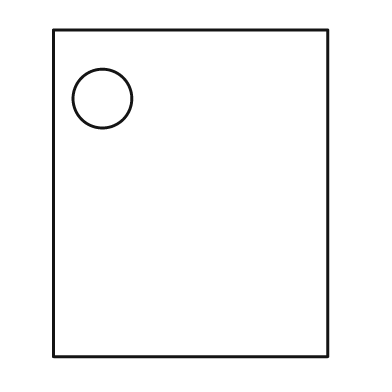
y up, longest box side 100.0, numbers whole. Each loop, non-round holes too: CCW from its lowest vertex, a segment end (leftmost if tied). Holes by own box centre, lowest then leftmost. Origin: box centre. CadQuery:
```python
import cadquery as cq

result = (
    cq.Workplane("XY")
    .moveTo(-42.0, -50.0)
    .lineTo(42.0, -50.0)
    .lineTo(42.0, 50.0)
    .lineTo(-42.0, 50.0)
    .close()
    .moveTo(-27.0, 29.0)
    .circle(9.0)
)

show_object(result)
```